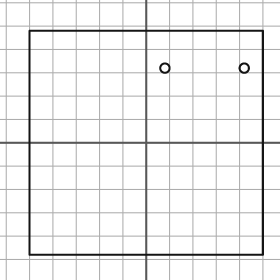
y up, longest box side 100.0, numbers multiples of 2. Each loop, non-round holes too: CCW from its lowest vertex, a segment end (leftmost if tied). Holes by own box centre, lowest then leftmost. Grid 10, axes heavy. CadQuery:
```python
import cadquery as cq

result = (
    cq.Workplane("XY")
    .moveTo(-50.0, -48.0)
    .lineTo(50.0, -48.0)
    .lineTo(50.0, 48.0)
    .lineTo(-50.0, 48.0)
    .close()
    .moveTo(8.0, 32.0)
    .circle(2.0)
    .moveTo(42.0, 32.0)
    .circle(2.0)
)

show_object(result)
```